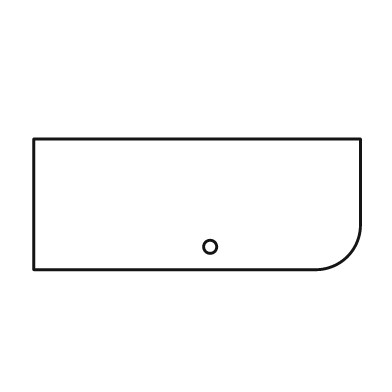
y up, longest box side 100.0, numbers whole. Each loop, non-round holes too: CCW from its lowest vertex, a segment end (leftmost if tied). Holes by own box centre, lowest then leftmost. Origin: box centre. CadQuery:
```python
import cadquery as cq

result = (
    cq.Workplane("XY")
    .moveTo(-50.0, -20.0)
    .lineTo(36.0, -20.0)
    .threePointArc((46.0, -16.0), (50.0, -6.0))
    .lineTo(50.0, 20.0)
    .lineTo(-50.0, 20.0)
    .close()
    .moveTo(4.0, -13.0)
    .circle(2.0)
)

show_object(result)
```